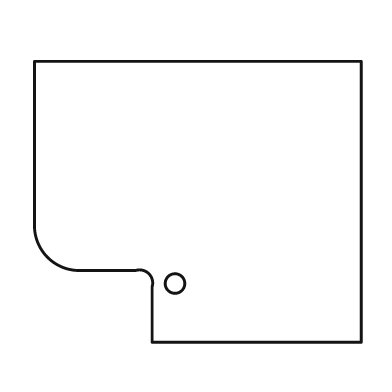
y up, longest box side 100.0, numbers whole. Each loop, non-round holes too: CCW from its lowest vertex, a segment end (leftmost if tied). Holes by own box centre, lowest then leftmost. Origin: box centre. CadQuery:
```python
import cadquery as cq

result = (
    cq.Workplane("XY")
    .moveTo(-14.0, -43.0)
    .lineTo(50.0, -43.0)
    .lineTo(50.0, 43.0)
    .lineTo(-50.0, 43.0)
    .lineTo(-50.0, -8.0)
    .threePointArc((-46.0, -17.0), (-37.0, -21.0))
    .lineTo(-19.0, -21.0)
    .threePointArc((-15.0, -22.0), (-14.0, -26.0))
    .close()
    .moveTo(-7.0, -25.0)
    .circle(3.0)
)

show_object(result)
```